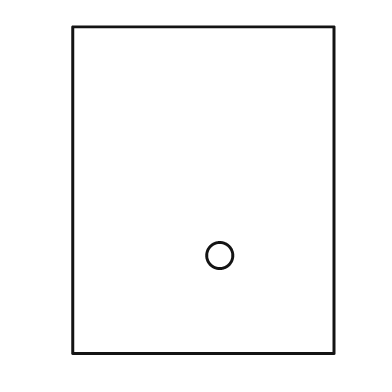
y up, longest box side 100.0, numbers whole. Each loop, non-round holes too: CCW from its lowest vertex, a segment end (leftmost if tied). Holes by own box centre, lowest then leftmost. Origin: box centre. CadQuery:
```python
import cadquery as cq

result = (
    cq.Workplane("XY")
    .moveTo(-40.0, -50.0)
    .lineTo(40.0, -50.0)
    .lineTo(40.0, 50.0)
    .lineTo(-40.0, 50.0)
    .close()
    .moveTo(5.0, -20.0)
    .circle(4.0)
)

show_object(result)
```